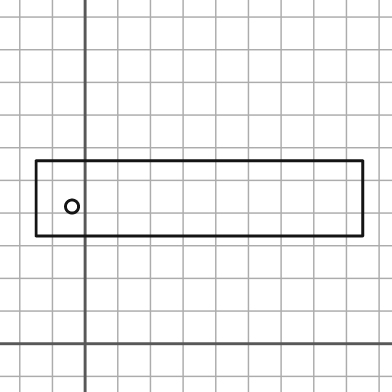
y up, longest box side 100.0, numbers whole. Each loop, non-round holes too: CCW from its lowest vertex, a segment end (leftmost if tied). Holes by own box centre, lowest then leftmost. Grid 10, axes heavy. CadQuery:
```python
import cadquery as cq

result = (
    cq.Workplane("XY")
    .moveTo(-15.0, 33.0)
    .lineTo(85.0, 33.0)
    .lineTo(85.0, 56.0)
    .lineTo(-15.0, 56.0)
    .close()
    .moveTo(-4.0, 42.0)
    .circle(2.0)
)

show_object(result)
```